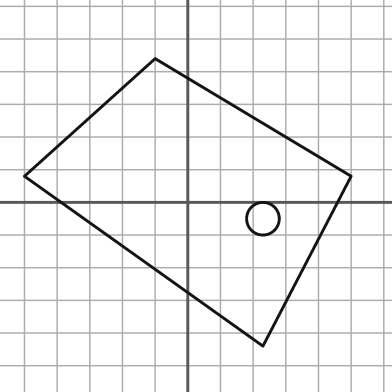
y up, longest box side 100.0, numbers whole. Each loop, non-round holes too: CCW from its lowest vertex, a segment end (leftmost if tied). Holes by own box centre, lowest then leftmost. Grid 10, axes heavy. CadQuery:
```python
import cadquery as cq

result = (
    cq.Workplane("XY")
    .moveTo(23.0, -44.0)
    .lineTo(50.0, 8.0)
    .lineTo(-10.0, 44.0)
    .lineTo(-50.0, 8.0)
    .close()
    .moveTo(23.0, -5.0)
    .circle(5.0)
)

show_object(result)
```